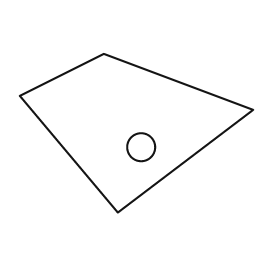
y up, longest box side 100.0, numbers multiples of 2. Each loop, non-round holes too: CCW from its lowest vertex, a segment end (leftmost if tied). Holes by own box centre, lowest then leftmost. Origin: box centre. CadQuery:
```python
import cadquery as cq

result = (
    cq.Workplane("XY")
    .moveTo(-8.0, -34.0)
    .lineTo(50.0, 10.0)
    .lineTo(-14.0, 34.0)
    .lineTo(-50.0, 16.0)
    .close()
    .moveTo(2.0, -6.0)
    .circle(6.0)
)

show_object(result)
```